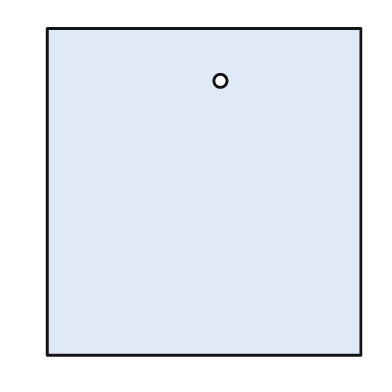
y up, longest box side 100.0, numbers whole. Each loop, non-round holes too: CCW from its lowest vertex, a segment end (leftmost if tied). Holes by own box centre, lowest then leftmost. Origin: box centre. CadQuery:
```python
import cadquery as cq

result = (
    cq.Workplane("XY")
    .moveTo(-48.0, -50.0)
    .lineTo(48.0, -50.0)
    .lineTo(48.0, 50.0)
    .lineTo(-48.0, 50.0)
    .close()
    .moveTo(5.0, 34.0)
    .circle(2.0)
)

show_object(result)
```